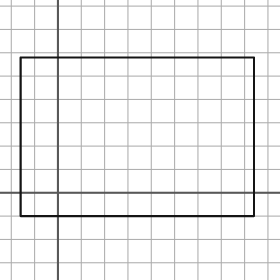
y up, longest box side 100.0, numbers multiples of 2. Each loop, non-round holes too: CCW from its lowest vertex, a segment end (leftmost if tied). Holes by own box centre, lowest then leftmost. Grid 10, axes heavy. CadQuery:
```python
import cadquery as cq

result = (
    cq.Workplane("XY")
    .moveTo(-16.0, -10.0)
    .lineTo(84.0, -10.0)
    .lineTo(84.0, 58.0)
    .lineTo(-16.0, 58.0)
    .close()
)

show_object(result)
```